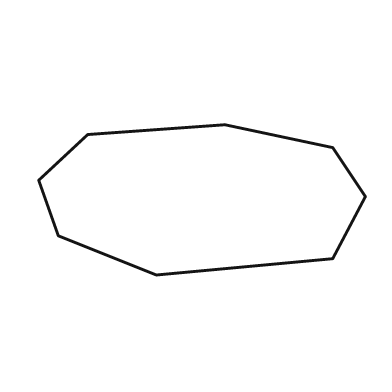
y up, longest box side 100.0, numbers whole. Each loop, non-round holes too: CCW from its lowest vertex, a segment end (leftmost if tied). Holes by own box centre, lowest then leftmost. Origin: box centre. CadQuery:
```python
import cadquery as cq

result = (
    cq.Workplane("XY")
    .moveTo(-14.0, -23.0)
    .lineTo(40.0, -18.0)
    .lineTo(50.0, 1.0)
    .lineTo(40.0, 16.0)
    .lineTo(7.0, 23.0)
    .lineTo(-35.0, 20.0)
    .lineTo(-50.0, 6.0)
    .lineTo(-44.0, -11.0)
    .close()
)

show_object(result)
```